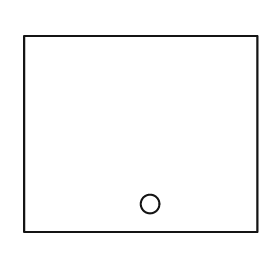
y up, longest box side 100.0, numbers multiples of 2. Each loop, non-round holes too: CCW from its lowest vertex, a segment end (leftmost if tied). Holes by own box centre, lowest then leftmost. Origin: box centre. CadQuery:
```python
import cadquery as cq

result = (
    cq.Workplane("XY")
    .moveTo(-50.0, -42.0)
    .lineTo(50.0, -42.0)
    .lineTo(50.0, 42.0)
    .lineTo(-50.0, 42.0)
    .close()
    .moveTo(4.0, -30.0)
    .circle(4.0)
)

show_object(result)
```